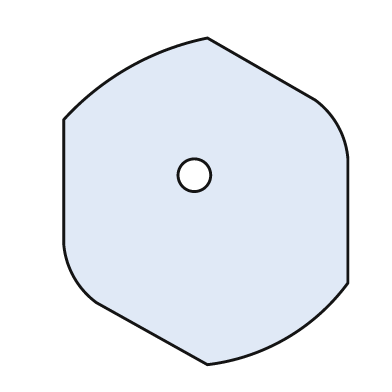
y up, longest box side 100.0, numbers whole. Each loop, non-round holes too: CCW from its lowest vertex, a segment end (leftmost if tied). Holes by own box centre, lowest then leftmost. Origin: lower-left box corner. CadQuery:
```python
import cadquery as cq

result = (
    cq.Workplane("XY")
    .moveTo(44.0, 0.0)
    .threePointArc((68.0, 8.0), (87.0, 25.0))
    .lineTo(87.0, 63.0)
    .threePointArc((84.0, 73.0), (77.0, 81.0))
    .lineTo(44.0, 100.0)
    .threePointArc((20.0, 91.0), (0.0, 75.0))
    .lineTo(0.0, 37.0)
    .threePointArc((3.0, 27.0), (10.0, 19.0))
    .close()
    .moveTo(40.0, 58.0)
    .circle(5.0)
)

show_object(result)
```